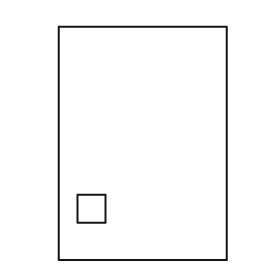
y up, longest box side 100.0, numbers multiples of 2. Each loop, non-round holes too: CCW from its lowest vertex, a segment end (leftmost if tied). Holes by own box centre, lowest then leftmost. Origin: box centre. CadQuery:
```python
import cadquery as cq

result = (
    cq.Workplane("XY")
    .moveTo(-36.0, -50.0)
    .lineTo(36.0, -50.0)
    .lineTo(36.0, 50.0)
    .lineTo(-36.0, 50.0)
    .close()
    .moveTo(-28.0, -34.0)
    .lineTo(-16.0, -34.0)
    .lineTo(-16.0, -22.0)
    .lineTo(-28.0, -22.0)
    .close()
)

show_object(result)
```